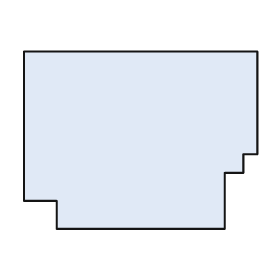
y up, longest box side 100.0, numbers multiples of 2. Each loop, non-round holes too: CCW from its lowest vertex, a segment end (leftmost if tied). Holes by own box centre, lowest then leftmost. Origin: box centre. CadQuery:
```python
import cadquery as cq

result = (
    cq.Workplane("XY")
    .moveTo(-36.0, -38.0)
    .lineTo(36.0, -38.0)
    .lineTo(36.0, -14.0)
    .lineTo(44.0, -14.0)
    .lineTo(44.0, -6.0)
    .lineTo(50.0, -6.0)
    .lineTo(50.0, 38.0)
    .lineTo(-50.0, 38.0)
    .lineTo(-50.0, -26.0)
    .lineTo(-36.0, -26.0)
    .close()
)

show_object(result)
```